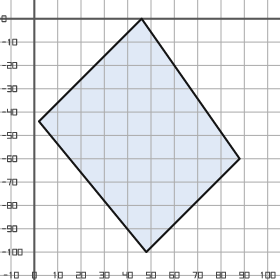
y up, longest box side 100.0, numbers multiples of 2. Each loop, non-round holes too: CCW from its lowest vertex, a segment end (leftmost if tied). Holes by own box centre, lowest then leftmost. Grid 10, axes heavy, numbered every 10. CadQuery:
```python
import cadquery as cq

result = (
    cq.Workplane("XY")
    .moveTo(48.0, -100.0)
    .lineTo(88.0, -60.0)
    .lineTo(46.0, 0.0)
    .lineTo(2.0, -44.0)
    .close()
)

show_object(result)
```